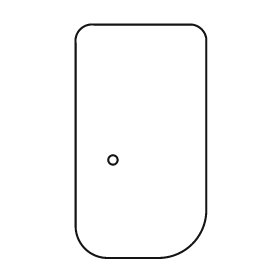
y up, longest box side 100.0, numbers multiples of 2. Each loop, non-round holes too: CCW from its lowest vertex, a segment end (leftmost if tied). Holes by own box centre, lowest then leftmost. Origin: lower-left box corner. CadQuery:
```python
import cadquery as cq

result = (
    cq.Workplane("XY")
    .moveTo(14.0, 0.0)
    .lineTo(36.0, 0.0)
    .threePointArc((50.0, 6.0), (56.0, 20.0))
    .lineTo(56.0, 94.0)
    .threePointArc((54.0, 98.0), (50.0, 100.0))
    .lineTo(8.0, 100.0)
    .threePointArc((2.0, 98.0), (0.0, 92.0))
    .lineTo(0.0, 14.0)
    .threePointArc((4.0, 4.0), (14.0, 0.0))
    .close()
    .moveTo(16.0, 42.0)
    .circle(2.0)
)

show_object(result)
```